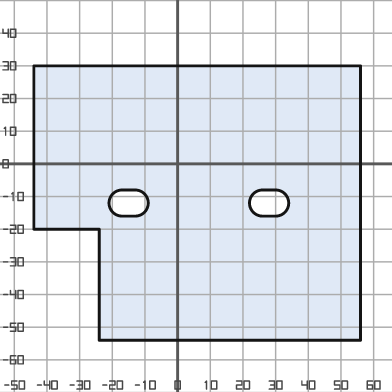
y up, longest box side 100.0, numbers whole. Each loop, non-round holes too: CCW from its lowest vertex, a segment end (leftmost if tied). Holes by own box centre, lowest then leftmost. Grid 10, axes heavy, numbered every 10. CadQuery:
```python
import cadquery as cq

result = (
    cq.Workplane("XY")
    .moveTo(-24.0, -54.0)
    .lineTo(56.0, -54.0)
    .lineTo(56.0, 30.0)
    .lineTo(-44.0, 30.0)
    .lineTo(-44.0, -20.0)
    .lineTo(-24.0, -20.0)
    .close()
    .moveTo(-17.0, -16.0)
    .lineTo(-13.0, -16.0)
    .threePointArc((-9.0, -12.0), (-13.0, -8.0))
    .lineTo(-17.0, -8.0)
    .threePointArc((-21.0, -12.0), (-17.0, -16.0))
    .close()
    .moveTo(26.0, -16.0)
    .lineTo(30.0, -16.0)
    .threePointArc((34.0, -12.0), (30.0, -8.0))
    .lineTo(26.0, -8.0)
    .threePointArc((22.0, -12.0), (26.0, -16.0))
    .close()
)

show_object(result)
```